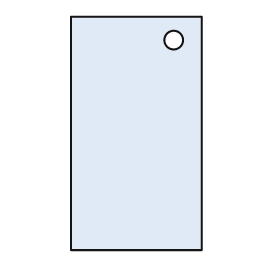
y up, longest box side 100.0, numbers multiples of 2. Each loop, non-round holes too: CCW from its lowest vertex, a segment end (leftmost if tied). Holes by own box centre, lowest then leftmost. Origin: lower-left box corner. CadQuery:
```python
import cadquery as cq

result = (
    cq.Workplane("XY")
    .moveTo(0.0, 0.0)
    .lineTo(56.0, 0.0)
    .lineTo(56.0, 100.0)
    .lineTo(0.0, 100.0)
    .close()
    .moveTo(44.0, 90.0)
    .circle(4.0)
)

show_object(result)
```